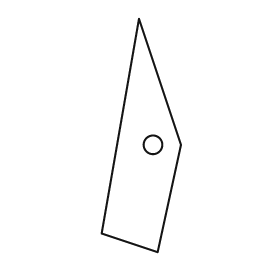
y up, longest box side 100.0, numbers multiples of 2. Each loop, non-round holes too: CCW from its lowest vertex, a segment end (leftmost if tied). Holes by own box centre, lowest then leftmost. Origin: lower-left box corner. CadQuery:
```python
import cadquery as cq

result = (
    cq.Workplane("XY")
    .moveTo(24.0, 0.0)
    .lineTo(34.0, 46.0)
    .lineTo(16.0, 100.0)
    .lineTo(0.0, 8.0)
    .close()
    .moveTo(22.0, 46.0)
    .circle(4.0)
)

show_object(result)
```